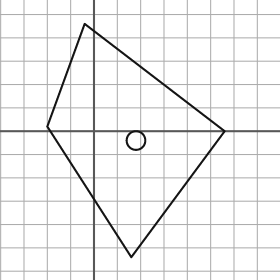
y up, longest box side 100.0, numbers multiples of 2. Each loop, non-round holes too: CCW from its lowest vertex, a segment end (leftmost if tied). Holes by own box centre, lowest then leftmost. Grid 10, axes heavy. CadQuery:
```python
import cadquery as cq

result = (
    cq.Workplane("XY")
    .moveTo(16.0, -54.0)
    .lineTo(56.0, 0.0)
    .lineTo(-4.0, 46.0)
    .lineTo(-20.0, 2.0)
    .close()
    .moveTo(18.0, -4.0)
    .circle(4.0)
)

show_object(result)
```